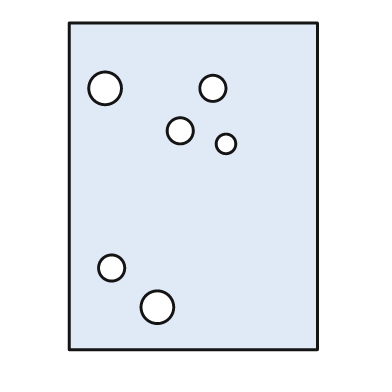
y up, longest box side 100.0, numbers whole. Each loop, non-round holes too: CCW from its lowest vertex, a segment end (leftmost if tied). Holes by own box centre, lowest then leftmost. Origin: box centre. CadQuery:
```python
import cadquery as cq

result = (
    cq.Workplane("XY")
    .moveTo(-38.0, -50.0)
    .lineTo(38.0, -50.0)
    .lineTo(38.0, 50.0)
    .lineTo(-38.0, 50.0)
    .close()
    .moveTo(-11.0, -37.0)
    .circle(5.0)
    .moveTo(-25.0, -25.0)
    .circle(4.0)
    .moveTo(10.0, 13.0)
    .circle(3.0)
    .moveTo(-4.0, 17.0)
    .circle(4.0)
    .moveTo(-27.0, 30.0)
    .circle(5.0)
    .moveTo(6.0, 30.0)
    .circle(4.0)
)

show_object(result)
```